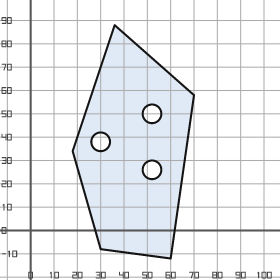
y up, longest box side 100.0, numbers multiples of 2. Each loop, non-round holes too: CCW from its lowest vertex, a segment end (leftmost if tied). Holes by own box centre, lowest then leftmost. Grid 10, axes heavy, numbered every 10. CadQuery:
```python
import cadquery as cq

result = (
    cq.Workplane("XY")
    .moveTo(60.0, -12.0)
    .lineTo(70.0, 58.0)
    .lineTo(36.0, 88.0)
    .lineTo(18.0, 34.0)
    .lineTo(30.0, -8.0)
    .close()
    .moveTo(52.0, 26.0)
    .circle(4.0)
    .moveTo(30.0, 38.0)
    .circle(4.0)
    .moveTo(52.0, 50.0)
    .circle(4.0)
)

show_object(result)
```